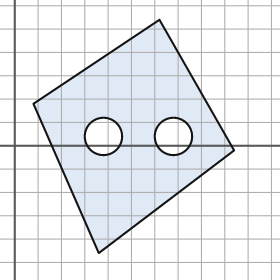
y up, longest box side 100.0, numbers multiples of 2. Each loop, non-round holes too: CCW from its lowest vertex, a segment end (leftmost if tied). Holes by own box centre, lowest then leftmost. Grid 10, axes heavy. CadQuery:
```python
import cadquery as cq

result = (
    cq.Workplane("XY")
    .moveTo(36.0, -46.0)
    .lineTo(94.0, -2.0)
    .lineTo(62.0, 54.0)
    .lineTo(8.0, 18.0)
    .close()
    .moveTo(38.0, 4.0)
    .circle(8.0)
    .moveTo(68.0, 4.0)
    .circle(8.0)
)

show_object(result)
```